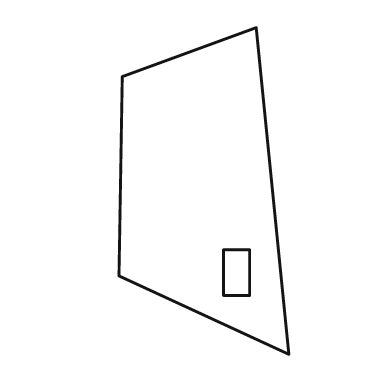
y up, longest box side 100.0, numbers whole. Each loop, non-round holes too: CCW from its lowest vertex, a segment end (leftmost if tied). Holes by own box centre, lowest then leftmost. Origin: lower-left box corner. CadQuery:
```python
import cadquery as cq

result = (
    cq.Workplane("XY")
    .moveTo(52.0, 0.0)
    .lineTo(42.0, 100.0)
    .lineTo(1.0, 85.0)
    .lineTo(0.0, 24.0)
    .close()
    .moveTo(32.0, 18.0)
    .lineTo(40.0, 18.0)
    .lineTo(40.0, 32.0)
    .lineTo(32.0, 32.0)
    .close()
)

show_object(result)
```